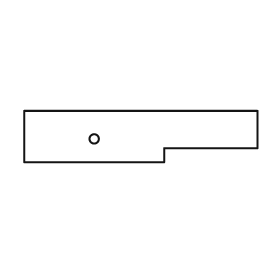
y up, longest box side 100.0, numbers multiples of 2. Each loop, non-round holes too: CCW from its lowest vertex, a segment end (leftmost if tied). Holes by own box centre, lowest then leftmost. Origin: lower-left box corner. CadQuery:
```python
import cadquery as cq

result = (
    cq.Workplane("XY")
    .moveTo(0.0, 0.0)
    .lineTo(60.0, 0.0)
    .lineTo(60.0, 6.0)
    .lineTo(100.0, 6.0)
    .lineTo(100.0, 22.0)
    .lineTo(0.0, 22.0)
    .close()
    .moveTo(30.0, 10.0)
    .circle(2.0)
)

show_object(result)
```